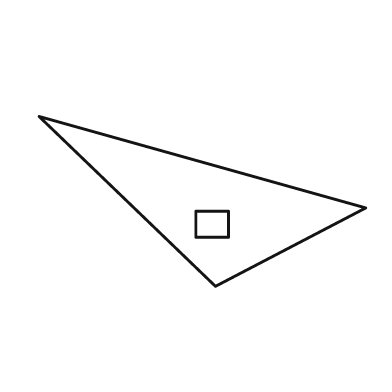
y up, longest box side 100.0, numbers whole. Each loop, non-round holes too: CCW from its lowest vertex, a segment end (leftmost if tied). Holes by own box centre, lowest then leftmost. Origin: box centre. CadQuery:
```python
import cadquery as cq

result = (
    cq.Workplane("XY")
    .moveTo(4.0, -26.0)
    .lineTo(50.0, -2.0)
    .lineTo(-50.0, 26.0)
    .close()
    .moveTo(-2.0, -11.0)
    .lineTo(8.0, -11.0)
    .lineTo(8.0, -3.0)
    .lineTo(-2.0, -3.0)
    .close()
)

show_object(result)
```